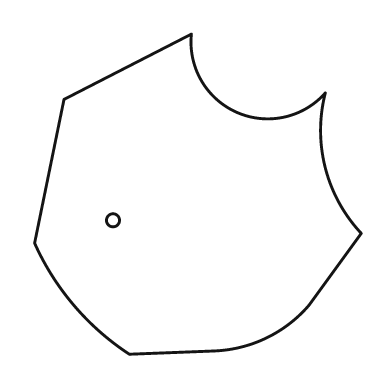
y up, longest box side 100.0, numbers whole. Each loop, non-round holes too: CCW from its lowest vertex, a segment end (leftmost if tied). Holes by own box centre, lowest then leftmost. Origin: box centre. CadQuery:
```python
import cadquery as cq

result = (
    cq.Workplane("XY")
    .moveTo(-21.0, -49.0)
    .lineTo(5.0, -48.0)
    .threePointArc((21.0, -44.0), (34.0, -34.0))
    .lineTo(50.0, -12.0)
    .threePointArc((39.0, 8.0), (39.0, 31.0))
    .threePointArc((12.0, 25.0), (-2.0, 49.0))
    .lineTo(-41.0, 29.0)
    .lineTo(-50.0, -15.0)
    .threePointArc((-38.0, -34.0), (-21.0, -49.0))
    .close()
    .moveTo(-26.0, -8.0)
    .circle(2.0)
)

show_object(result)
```